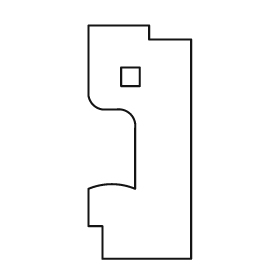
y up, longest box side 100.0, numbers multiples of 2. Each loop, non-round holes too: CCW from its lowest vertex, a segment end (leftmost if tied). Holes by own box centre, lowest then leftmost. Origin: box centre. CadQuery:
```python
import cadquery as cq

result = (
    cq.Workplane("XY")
    .moveTo(-16.0, -50.0)
    .lineTo(22.0, -50.0)
    .lineTo(22.0, 44.0)
    .lineTo(4.0, 44.0)
    .lineTo(4.0, 50.0)
    .lineTo(-22.0, 50.0)
    .lineTo(-22.0, 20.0)
    .threePointArc((-20.0, 16.0), (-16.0, 14.0))
    .lineTo(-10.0, 14.0)
    .threePointArc((-4.0, 12.0), (-2.0, 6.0))
    .lineTo(-2.0, -20.0)
    .threePointArc((-12.0, -18.0), (-22.0, -20.0))
    .lineTo(-22.0, -36.0)
    .lineTo(-16.0, -36.0)
    .close()
    .moveTo(-8.0, 24.0)
    .lineTo(0.0, 24.0)
    .lineTo(0.0, 32.0)
    .lineTo(-8.0, 32.0)
    .close()
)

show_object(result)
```